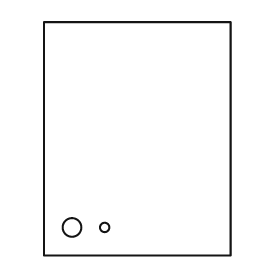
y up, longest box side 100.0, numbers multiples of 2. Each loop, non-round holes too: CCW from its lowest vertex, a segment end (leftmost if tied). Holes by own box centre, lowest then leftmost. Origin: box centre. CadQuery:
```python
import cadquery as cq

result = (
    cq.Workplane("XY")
    .moveTo(-40.0, -50.0)
    .lineTo(40.0, -50.0)
    .lineTo(40.0, 50.0)
    .lineTo(-40.0, 50.0)
    .close()
    .moveTo(-28.0, -38.0)
    .circle(4.0)
    .moveTo(-14.0, -38.0)
    .circle(2.0)
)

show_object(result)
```